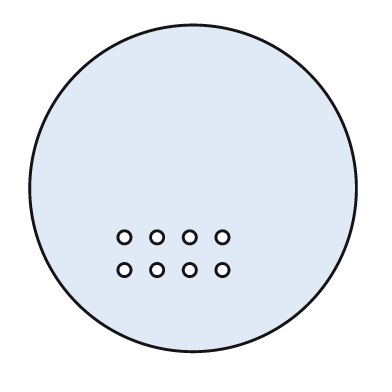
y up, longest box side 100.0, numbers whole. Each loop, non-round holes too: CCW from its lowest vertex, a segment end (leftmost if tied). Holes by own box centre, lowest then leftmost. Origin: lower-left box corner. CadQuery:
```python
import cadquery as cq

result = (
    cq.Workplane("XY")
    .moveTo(50.0, 50.0)
    .circle(50.0)
    .moveTo(29.0, 25.0)
    .circle(2.0)
    .moveTo(39.0, 25.0)
    .circle(2.0)
    .moveTo(49.0, 25.0)
    .circle(2.0)
    .moveTo(59.0, 25.0)
    .circle(2.0)
    .moveTo(29.0, 35.0)
    .circle(2.0)
    .moveTo(39.0, 35.0)
    .circle(2.0)
    .moveTo(49.0, 35.0)
    .circle(2.0)
    .moveTo(59.0, 35.0)
    .circle(2.0)
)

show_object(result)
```